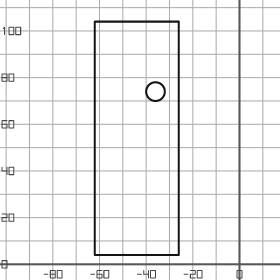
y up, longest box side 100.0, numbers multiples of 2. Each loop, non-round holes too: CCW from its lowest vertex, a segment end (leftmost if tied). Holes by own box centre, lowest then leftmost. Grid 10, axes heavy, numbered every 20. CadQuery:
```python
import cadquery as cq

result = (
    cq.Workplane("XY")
    .moveTo(-62.0, 4.0)
    .lineTo(-26.0, 4.0)
    .lineTo(-26.0, 104.0)
    .lineTo(-62.0, 104.0)
    .close()
    .moveTo(-36.0, 74.0)
    .circle(4.0)
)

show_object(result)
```